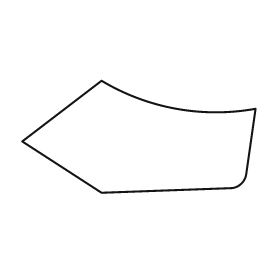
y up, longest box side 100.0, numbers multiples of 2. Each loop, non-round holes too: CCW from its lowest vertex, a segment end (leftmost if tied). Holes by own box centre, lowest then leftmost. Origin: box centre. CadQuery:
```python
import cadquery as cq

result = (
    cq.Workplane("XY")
    .moveTo(-16.0, -24.0)
    .lineTo(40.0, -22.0)
    .threePointArc((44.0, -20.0), (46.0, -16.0))
    .lineTo(50.0, 12.0)
    .threePointArc((16.0, 12.0), (-16.0, 24.0))
    .lineTo(-50.0, -2.0)
    .close()
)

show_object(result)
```